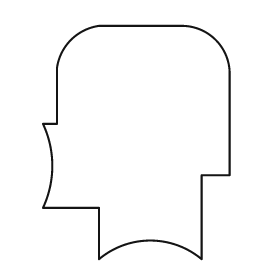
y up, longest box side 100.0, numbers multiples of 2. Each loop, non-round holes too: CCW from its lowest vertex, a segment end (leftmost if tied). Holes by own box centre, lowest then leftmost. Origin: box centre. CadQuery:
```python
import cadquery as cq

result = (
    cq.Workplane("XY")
    .moveTo(-16.0, -50.0)
    .threePointArc((6.0, -42.0), (28.0, -50.0))
    .lineTo(28.0, -14.0)
    .lineTo(40.0, -14.0)
    .lineTo(40.0, 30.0)
    .threePointArc((34.0, 44.0), (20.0, 50.0))
    .lineTo(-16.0, 50.0)
    .threePointArc((-28.0, 44.0), (-34.0, 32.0))
    .lineTo(-34.0, 8.0)
    .lineTo(-40.0, 8.0)
    .threePointArc((-36.0, -10.0), (-40.0, -28.0))
    .lineTo(-16.0, -28.0)
    .close()
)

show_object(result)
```